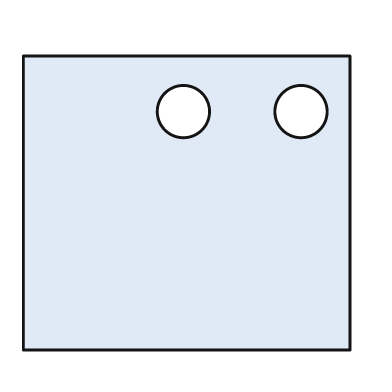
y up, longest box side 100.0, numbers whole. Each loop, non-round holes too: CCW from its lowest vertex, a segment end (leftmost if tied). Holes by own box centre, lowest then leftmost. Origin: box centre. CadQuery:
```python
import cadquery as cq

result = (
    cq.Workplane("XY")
    .moveTo(-50.0, -45.0)
    .lineTo(50.0, -45.0)
    .lineTo(50.0, 45.0)
    .lineTo(-50.0, 45.0)
    .close()
    .moveTo(-1.0, 28.0)
    .circle(8.0)
    .moveTo(35.0, 28.0)
    .circle(8.0)
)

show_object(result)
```